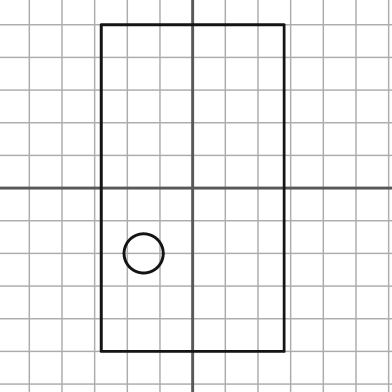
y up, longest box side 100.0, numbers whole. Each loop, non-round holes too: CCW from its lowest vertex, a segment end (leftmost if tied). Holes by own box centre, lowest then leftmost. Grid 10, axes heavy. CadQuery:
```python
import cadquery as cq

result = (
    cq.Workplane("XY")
    .moveTo(-28.0, -50.0)
    .lineTo(28.0, -50.0)
    .lineTo(28.0, 50.0)
    .lineTo(-28.0, 50.0)
    .close()
    .moveTo(-15.0, -20.0)
    .circle(6.0)
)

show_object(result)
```